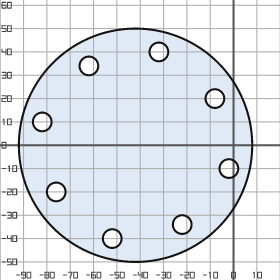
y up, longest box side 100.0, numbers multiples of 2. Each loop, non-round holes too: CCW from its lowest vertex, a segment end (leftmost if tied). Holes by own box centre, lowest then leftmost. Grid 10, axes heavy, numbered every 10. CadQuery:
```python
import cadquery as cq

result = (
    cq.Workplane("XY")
    .moveTo(-42.0, 0.0)
    .circle(50.0)
    .moveTo(-52.0, -40.0)
    .circle(4.0)
    .moveTo(-22.0, -34.0)
    .circle(4.0)
    .moveTo(-76.0, -20.0)
    .circle(4.0)
    .moveTo(-2.0, -10.0)
    .circle(4.0)
    .moveTo(-82.0, 10.0)
    .circle(4.0)
    .moveTo(-8.0, 20.0)
    .circle(4.0)
    .moveTo(-62.0, 34.0)
    .circle(4.0)
    .moveTo(-32.0, 40.0)
    .circle(4.0)
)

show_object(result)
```